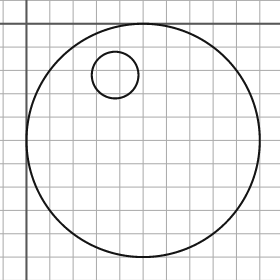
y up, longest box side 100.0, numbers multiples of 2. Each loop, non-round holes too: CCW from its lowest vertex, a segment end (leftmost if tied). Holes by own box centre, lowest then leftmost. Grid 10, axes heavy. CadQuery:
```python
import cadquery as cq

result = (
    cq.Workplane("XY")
    .moveTo(50.0, -50.0)
    .circle(50.0)
    .moveTo(38.0, -22.0)
    .circle(10.0)
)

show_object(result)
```